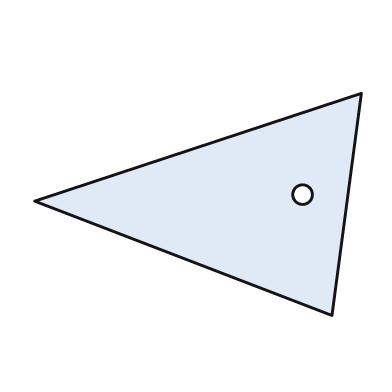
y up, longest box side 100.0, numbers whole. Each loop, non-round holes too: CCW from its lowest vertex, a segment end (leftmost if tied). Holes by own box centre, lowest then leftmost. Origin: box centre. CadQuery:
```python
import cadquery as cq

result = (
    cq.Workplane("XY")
    .moveTo(41.0, -34.0)
    .lineTo(50.0, 34.0)
    .lineTo(-50.0, 1.0)
    .close()
    .moveTo(32.0, 3.0)
    .circle(3.0)
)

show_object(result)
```